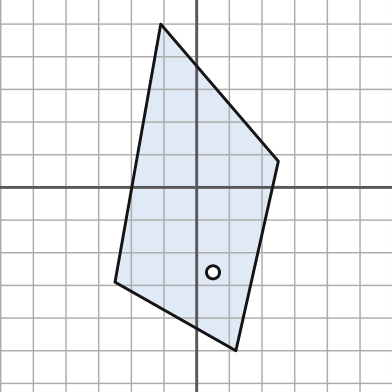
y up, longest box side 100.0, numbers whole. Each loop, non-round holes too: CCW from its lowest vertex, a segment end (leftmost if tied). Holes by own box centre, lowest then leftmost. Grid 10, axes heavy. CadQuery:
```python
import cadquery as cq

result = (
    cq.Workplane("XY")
    .moveTo(12.0, -50.0)
    .lineTo(25.0, 8.0)
    .lineTo(-11.0, 50.0)
    .lineTo(-25.0, -29.0)
    .close()
    .moveTo(5.0, -26.0)
    .circle(2.0)
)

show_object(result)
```